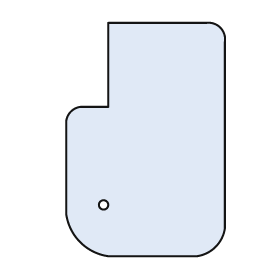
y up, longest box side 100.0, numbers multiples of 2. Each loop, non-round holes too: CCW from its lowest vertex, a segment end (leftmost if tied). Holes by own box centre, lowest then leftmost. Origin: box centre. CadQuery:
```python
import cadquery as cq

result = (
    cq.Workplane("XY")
    .moveTo(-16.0, -50.0)
    .lineTo(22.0, -50.0)
    .threePointArc((30.0, -46.0), (34.0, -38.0))
    .lineTo(34.0, 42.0)
    .threePointArc((32.0, 48.0), (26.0, 50.0))
    .lineTo(-16.0, 50.0)
    .lineTo(-16.0, 14.0)
    .lineTo(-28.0, 14.0)
    .threePointArc((-32.0, 12.0), (-34.0, 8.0))
    .lineTo(-34.0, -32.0)
    .threePointArc((-28.0, -44.0), (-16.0, -50.0))
    .close()
    .moveTo(-18.0, -28.0)
    .circle(2.0)
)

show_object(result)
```